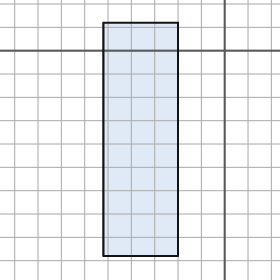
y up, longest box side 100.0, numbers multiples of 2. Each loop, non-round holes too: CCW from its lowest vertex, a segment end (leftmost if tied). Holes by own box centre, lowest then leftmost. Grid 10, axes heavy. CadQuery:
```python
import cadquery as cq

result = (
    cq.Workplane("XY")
    .moveTo(-52.0, -88.0)
    .lineTo(-20.0, -88.0)
    .lineTo(-20.0, 12.0)
    .lineTo(-52.0, 12.0)
    .close()
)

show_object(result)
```